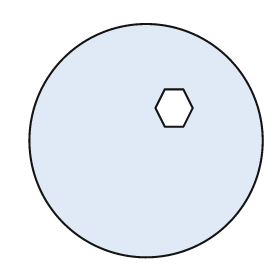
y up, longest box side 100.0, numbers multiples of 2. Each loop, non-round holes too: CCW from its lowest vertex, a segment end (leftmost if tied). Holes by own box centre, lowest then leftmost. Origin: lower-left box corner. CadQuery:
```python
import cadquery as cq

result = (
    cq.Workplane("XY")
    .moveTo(50.0, 50.0)
    .circle(50.0)
    .moveTo(58.0, 56.0)
    .lineTo(66.0, 56.0)
    .lineTo(70.0, 64.0)
    .lineTo(66.0, 72.0)
    .lineTo(58.0, 72.0)
    .lineTo(54.0, 64.0)
    .close()
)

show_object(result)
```